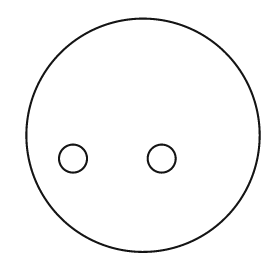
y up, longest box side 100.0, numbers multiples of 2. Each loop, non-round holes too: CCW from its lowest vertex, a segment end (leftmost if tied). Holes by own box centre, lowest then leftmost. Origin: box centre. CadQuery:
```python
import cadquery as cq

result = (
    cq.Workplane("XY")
    .moveTo(0.0, 0.0)
    .circle(50.0)
    .moveTo(-30.0, -10.0)
    .circle(6.0)
    .moveTo(8.0, -10.0)
    .circle(6.0)
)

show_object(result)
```